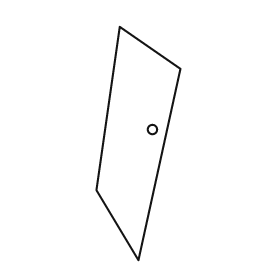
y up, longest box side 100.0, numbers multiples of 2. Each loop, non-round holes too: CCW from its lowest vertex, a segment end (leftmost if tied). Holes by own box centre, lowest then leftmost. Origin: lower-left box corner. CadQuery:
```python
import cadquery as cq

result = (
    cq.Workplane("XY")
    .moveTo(18.0, 0.0)
    .lineTo(36.0, 82.0)
    .lineTo(10.0, 100.0)
    .lineTo(0.0, 30.0)
    .close()
    .moveTo(24.0, 56.0)
    .circle(2.0)
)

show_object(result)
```